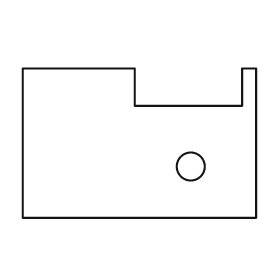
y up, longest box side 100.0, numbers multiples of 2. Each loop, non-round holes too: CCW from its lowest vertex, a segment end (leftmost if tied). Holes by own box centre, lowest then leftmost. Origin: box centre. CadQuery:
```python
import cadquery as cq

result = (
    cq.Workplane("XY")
    .moveTo(-50.0, -32.0)
    .lineTo(50.0, -32.0)
    .lineTo(50.0, 32.0)
    .lineTo(44.0, 32.0)
    .lineTo(44.0, 16.0)
    .lineTo(-2.0, 16.0)
    .lineTo(-2.0, 32.0)
    .lineTo(-50.0, 32.0)
    .close()
    .moveTo(22.0, -10.0)
    .circle(6.0)
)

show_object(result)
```